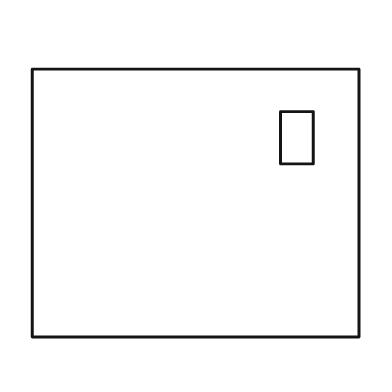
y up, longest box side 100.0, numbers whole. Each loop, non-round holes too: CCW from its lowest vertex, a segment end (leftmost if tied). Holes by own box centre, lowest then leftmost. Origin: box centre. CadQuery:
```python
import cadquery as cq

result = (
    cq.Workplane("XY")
    .moveTo(-50.0, -41.0)
    .lineTo(50.0, -41.0)
    .lineTo(50.0, 41.0)
    .lineTo(-50.0, 41.0)
    .close()
    .moveTo(26.0, 12.0)
    .lineTo(36.0, 12.0)
    .lineTo(36.0, 28.0)
    .lineTo(26.0, 28.0)
    .close()
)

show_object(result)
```